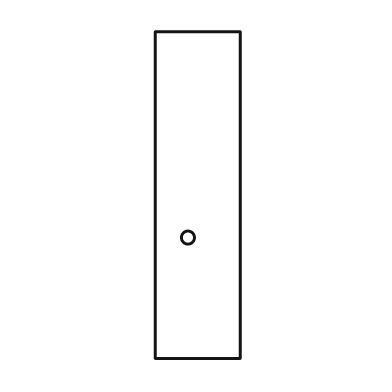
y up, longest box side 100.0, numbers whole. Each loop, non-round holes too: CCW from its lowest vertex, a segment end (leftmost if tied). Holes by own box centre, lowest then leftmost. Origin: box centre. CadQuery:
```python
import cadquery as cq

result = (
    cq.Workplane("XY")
    .moveTo(-13.0, -50.0)
    .lineTo(13.0, -50.0)
    .lineTo(13.0, 50.0)
    .lineTo(-13.0, 50.0)
    .close()
    .moveTo(-3.0, -13.0)
    .circle(2.0)
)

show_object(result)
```